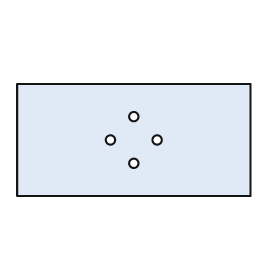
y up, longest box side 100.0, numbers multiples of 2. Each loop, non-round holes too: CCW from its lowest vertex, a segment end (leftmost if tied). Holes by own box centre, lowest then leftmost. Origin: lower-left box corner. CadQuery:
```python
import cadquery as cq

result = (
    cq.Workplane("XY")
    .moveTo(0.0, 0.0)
    .lineTo(100.0, 0.0)
    .lineTo(100.0, 48.0)
    .lineTo(0.0, 48.0)
    .close()
    .moveTo(50.0, 14.0)
    .circle(2.0)
    .moveTo(40.0, 24.0)
    .circle(2.0)
    .moveTo(60.0, 24.0)
    .circle(2.0)
    .moveTo(50.0, 34.0)
    .circle(2.0)
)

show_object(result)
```